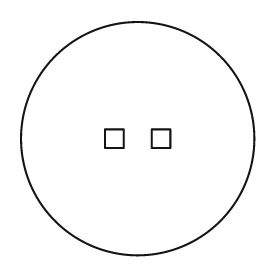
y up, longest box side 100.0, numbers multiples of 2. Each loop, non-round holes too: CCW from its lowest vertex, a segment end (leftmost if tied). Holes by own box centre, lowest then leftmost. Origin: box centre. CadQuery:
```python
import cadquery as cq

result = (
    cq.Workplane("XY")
    .moveTo(0.0, 0.0)
    .circle(50.0)
    .moveTo(-14.0, -4.0)
    .lineTo(-6.0, -4.0)
    .lineTo(-6.0, 4.0)
    .lineTo(-14.0, 4.0)
    .close()
    .moveTo(6.0, -4.0)
    .lineTo(14.0, -4.0)
    .lineTo(14.0, 4.0)
    .lineTo(6.0, 4.0)
    .close()
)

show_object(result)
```